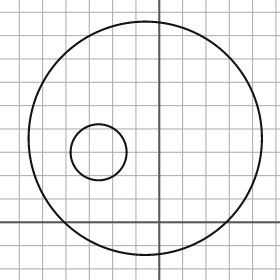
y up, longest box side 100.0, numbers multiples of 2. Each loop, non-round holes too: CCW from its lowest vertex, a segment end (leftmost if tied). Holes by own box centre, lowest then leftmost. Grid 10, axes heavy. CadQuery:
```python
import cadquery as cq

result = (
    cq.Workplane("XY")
    .moveTo(-6.0, 36.0)
    .circle(50.0)
    .moveTo(-26.0, 30.0)
    .circle(12.0)
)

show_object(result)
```